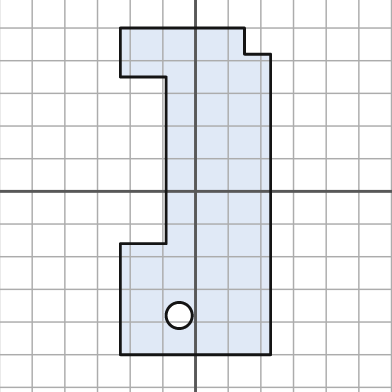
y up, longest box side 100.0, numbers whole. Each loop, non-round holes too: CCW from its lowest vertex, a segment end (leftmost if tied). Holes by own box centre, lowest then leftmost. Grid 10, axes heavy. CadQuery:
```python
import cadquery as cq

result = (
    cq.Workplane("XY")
    .moveTo(-23.0, -50.0)
    .lineTo(23.0, -50.0)
    .lineTo(23.0, 42.0)
    .lineTo(15.0, 42.0)
    .lineTo(15.0, 50.0)
    .lineTo(-23.0, 50.0)
    .lineTo(-23.0, 35.0)
    .lineTo(-9.0, 35.0)
    .lineTo(-9.0, -16.0)
    .lineTo(-23.0, -16.0)
    .close()
    .moveTo(-5.0, -38.0)
    .circle(4.0)
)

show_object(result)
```